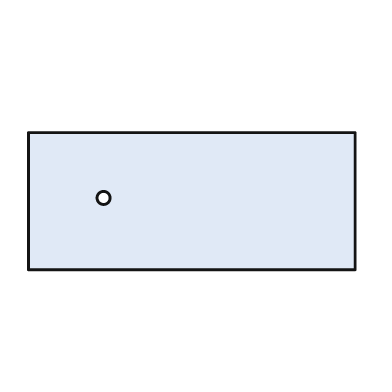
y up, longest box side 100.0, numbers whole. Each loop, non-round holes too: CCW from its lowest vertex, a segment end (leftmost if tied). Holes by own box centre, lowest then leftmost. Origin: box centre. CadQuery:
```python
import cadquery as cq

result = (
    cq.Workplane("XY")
    .moveTo(-50.0, -21.0)
    .lineTo(50.0, -21.0)
    .lineTo(50.0, 21.0)
    .lineTo(-50.0, 21.0)
    .close()
    .moveTo(-27.0, 1.0)
    .circle(2.0)
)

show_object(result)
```